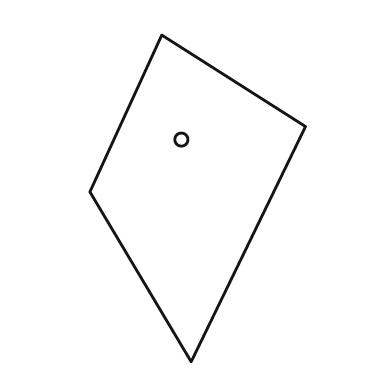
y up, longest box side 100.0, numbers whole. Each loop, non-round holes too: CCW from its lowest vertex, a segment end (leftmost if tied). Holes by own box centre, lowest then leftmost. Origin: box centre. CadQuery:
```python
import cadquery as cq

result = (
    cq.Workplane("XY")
    .moveTo(-2.0, -50.0)
    .lineTo(33.0, 22.0)
    .lineTo(-11.0, 50.0)
    .lineTo(-33.0, 2.0)
    .close()
    .moveTo(-5.0, 18.0)
    .circle(2.0)
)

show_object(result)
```